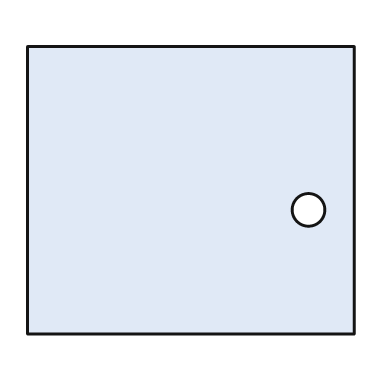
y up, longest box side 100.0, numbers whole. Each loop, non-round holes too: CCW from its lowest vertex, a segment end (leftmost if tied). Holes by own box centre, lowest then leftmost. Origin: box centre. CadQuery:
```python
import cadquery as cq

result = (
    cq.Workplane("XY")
    .moveTo(-50.0, -44.0)
    .lineTo(50.0, -44.0)
    .lineTo(50.0, 44.0)
    .lineTo(-50.0, 44.0)
    .close()
    .moveTo(36.0, -6.0)
    .circle(5.0)
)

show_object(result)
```